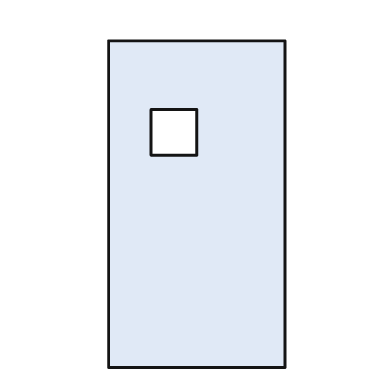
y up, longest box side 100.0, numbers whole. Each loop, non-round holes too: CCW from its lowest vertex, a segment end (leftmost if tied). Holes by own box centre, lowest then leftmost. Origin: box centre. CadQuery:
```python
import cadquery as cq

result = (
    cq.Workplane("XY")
    .moveTo(-27.0, -50.0)
    .lineTo(27.0, -50.0)
    .lineTo(27.0, 50.0)
    .lineTo(-27.0, 50.0)
    .close()
    .moveTo(-14.0, 15.0)
    .lineTo(0.0, 15.0)
    .lineTo(0.0, 29.0)
    .lineTo(-14.0, 29.0)
    .close()
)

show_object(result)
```